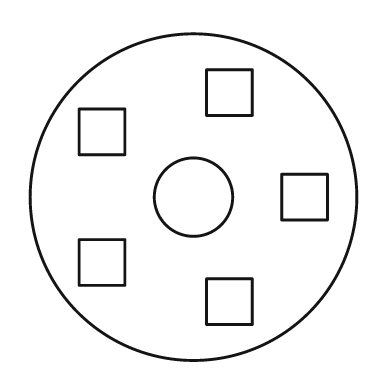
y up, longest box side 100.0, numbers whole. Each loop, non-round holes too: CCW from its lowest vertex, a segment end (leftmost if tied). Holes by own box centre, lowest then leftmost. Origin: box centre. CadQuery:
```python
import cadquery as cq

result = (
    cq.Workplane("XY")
    .moveTo(0.0, 0.0)
    .circle(50.0)
    .moveTo(4.0, -39.0)
    .lineTo(18.0, -39.0)
    .lineTo(18.0, -25.0)
    .lineTo(4.0, -25.0)
    .close()
    .moveTo(-35.0, -27.0)
    .lineTo(-21.0, -27.0)
    .lineTo(-21.0, -13.0)
    .lineTo(-35.0, -13.0)
    .close()
    .moveTo(0.0, 0.0)
    .circle(12.0)
    .moveTo(27.0, -7.0)
    .lineTo(41.0, -7.0)
    .lineTo(41.0, 7.0)
    .lineTo(27.0, 7.0)
    .close()
    .moveTo(-35.0, 13.0)
    .lineTo(-21.0, 13.0)
    .lineTo(-21.0, 27.0)
    .lineTo(-35.0, 27.0)
    .close()
    .moveTo(4.0, 25.0)
    .lineTo(18.0, 25.0)
    .lineTo(18.0, 39.0)
    .lineTo(4.0, 39.0)
    .close()
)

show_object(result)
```